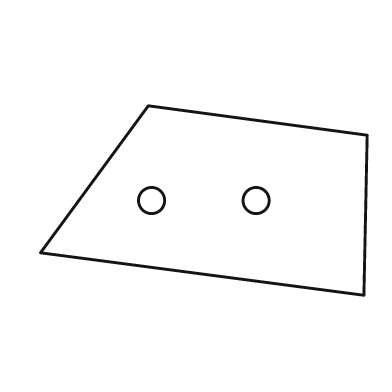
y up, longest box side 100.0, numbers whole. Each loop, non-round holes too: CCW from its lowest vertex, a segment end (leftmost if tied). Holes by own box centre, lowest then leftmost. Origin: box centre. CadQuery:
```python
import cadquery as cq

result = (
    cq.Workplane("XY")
    .moveTo(49.0, -29.0)
    .lineTo(50.0, 20.0)
    .lineTo(-17.0, 29.0)
    .lineTo(-50.0, -16.0)
    .close()
    .moveTo(-16.0, 0.0)
    .circle(4.0)
    .moveTo(16.0, 0.0)
    .circle(4.0)
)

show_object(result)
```